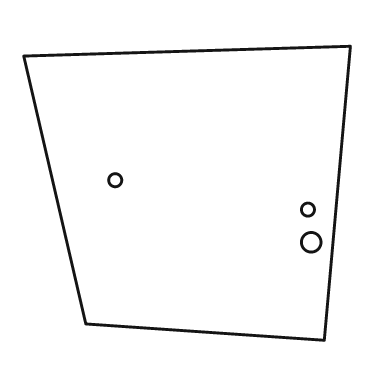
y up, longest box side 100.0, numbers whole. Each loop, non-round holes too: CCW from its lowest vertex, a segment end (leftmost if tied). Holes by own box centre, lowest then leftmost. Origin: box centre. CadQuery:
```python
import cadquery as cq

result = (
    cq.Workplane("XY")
    .moveTo(42.0, -45.0)
    .lineTo(50.0, 45.0)
    .lineTo(-50.0, 42.0)
    .lineTo(-31.0, -40.0)
    .close()
    .moveTo(38.0, -15.0)
    .circle(3.0)
    .moveTo(37.0, -5.0)
    .circle(2.0)
    .moveTo(-22.0, 4.0)
    .circle(2.0)
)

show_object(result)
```